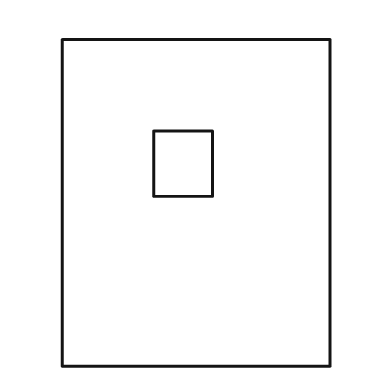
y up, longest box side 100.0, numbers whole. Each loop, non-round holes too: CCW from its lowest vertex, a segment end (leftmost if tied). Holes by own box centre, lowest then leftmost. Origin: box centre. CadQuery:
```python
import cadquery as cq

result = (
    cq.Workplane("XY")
    .moveTo(-41.0, -50.0)
    .lineTo(41.0, -50.0)
    .lineTo(41.0, 50.0)
    .lineTo(-41.0, 50.0)
    .close()
    .moveTo(-13.0, 2.0)
    .lineTo(5.0, 2.0)
    .lineTo(5.0, 22.0)
    .lineTo(-13.0, 22.0)
    .close()
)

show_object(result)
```